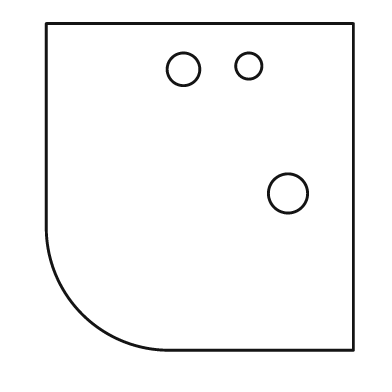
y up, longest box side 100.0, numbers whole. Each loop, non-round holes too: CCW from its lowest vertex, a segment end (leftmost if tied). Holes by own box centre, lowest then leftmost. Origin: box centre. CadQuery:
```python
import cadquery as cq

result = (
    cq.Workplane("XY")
    .moveTo(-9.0, -50.0)
    .lineTo(47.0, -50.0)
    .lineTo(47.0, 50.0)
    .lineTo(-47.0, 50.0)
    .lineTo(-47.0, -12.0)
    .threePointArc((-36.0, -39.0), (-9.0, -50.0))
    .close()
    .moveTo(27.0, -2.0)
    .circle(6.0)
    .moveTo(-5.0, 36.0)
    .circle(5.0)
    .moveTo(15.0, 37.0)
    .circle(4.0)
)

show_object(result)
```